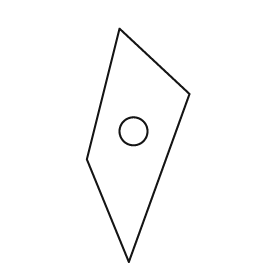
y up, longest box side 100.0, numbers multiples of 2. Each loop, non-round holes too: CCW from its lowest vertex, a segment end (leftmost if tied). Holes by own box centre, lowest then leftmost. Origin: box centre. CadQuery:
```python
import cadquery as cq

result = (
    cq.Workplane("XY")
    .moveTo(-4.0, -50.0)
    .lineTo(22.0, 22.0)
    .lineTo(-8.0, 50.0)
    .lineTo(-22.0, -6.0)
    .close()
    .moveTo(-2.0, 6.0)
    .circle(6.0)
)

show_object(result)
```